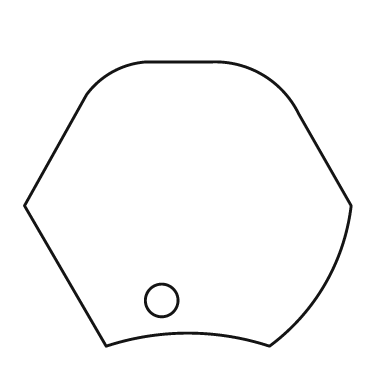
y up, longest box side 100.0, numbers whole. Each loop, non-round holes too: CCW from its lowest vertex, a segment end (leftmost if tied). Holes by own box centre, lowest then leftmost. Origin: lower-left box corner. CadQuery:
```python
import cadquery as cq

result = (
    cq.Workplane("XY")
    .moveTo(25.0, 0.0)
    .threePointArc((50.0, 4.0), (75.0, 0.0))
    .threePointArc((92.0, 19.0), (100.0, 43.0))
    .lineTo(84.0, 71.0)
    .threePointArc((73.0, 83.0), (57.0, 87.0))
    .lineTo(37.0, 87.0)
    .threePointArc((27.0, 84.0), (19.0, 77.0))
    .lineTo(0.0, 43.0)
    .close()
    .moveTo(42.0, 14.0)
    .circle(5.0)
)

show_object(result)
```